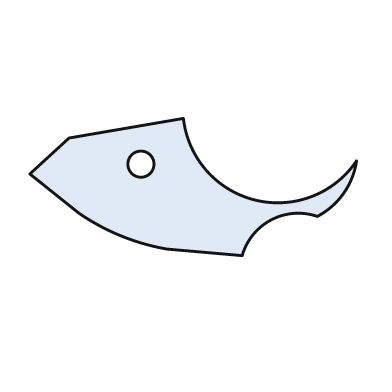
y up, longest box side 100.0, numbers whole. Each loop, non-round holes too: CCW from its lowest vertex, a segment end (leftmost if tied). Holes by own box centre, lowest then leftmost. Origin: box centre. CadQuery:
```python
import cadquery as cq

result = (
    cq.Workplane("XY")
    .moveTo(15.0, -21.0)
    .threePointArc((24.0, -10.0), (38.0, -9.0))
    .threePointArc((46.0, -2.0), (50.0, 8.0))
    .threePointArc((19.0, -4.0), (-3.0, 21.0))
    .lineTo(-38.0, 15.0)
    .lineTo(-50.0, 4.0)
    .lineTo(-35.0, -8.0)
    .threePointArc((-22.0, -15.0), (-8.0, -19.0))
    .close()
    .moveTo(-16.0, 7.0)
    .circle(4.0)
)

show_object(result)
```